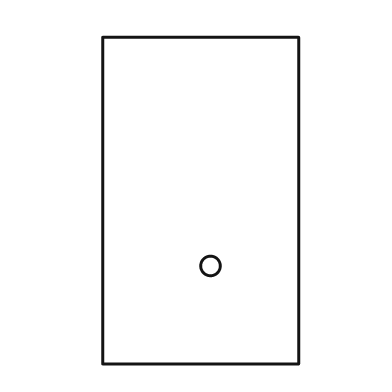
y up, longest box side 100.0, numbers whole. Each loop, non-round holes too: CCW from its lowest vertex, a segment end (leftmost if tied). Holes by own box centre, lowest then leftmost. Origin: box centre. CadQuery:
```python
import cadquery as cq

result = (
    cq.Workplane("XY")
    .moveTo(-30.0, -50.0)
    .lineTo(30.0, -50.0)
    .lineTo(30.0, 50.0)
    .lineTo(-30.0, 50.0)
    .close()
    .moveTo(3.0, -20.0)
    .circle(3.0)
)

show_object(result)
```